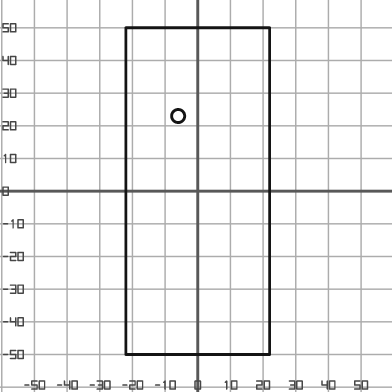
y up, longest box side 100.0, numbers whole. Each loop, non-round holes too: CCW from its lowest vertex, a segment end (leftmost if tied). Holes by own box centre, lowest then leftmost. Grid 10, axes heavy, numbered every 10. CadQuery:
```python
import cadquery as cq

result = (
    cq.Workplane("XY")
    .moveTo(-22.0, -50.0)
    .lineTo(22.0, -50.0)
    .lineTo(22.0, 50.0)
    .lineTo(-22.0, 50.0)
    .close()
    .moveTo(-6.0, 23.0)
    .circle(2.0)
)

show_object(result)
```